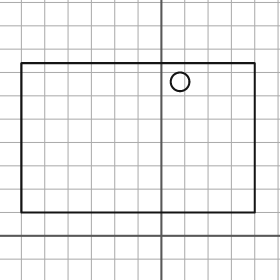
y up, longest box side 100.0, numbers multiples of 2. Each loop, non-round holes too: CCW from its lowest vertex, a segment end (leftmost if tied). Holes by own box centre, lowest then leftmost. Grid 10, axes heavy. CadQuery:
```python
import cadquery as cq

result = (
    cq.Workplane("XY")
    .moveTo(-60.0, 10.0)
    .lineTo(40.0, 10.0)
    .lineTo(40.0, 74.0)
    .lineTo(-60.0, 74.0)
    .close()
    .moveTo(8.0, 66.0)
    .circle(4.0)
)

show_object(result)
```